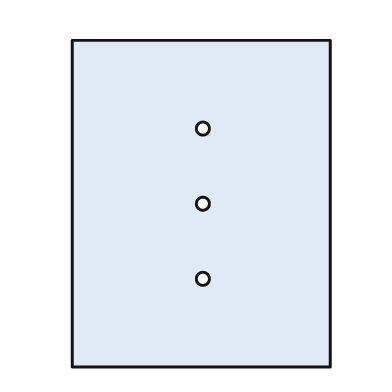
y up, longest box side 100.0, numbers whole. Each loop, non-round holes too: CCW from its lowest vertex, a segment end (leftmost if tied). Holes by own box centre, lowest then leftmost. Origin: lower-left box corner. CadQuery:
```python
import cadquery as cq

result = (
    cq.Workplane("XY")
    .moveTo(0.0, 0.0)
    .lineTo(79.0, 0.0)
    .lineTo(79.0, 100.0)
    .lineTo(0.0, 100.0)
    .close()
    .moveTo(40.0, 27.0)
    .circle(2.0)
    .moveTo(40.0, 50.0)
    .circle(2.0)
    .moveTo(40.0, 73.0)
    .circle(2.0)
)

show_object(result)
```